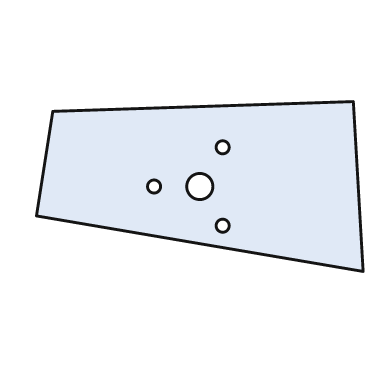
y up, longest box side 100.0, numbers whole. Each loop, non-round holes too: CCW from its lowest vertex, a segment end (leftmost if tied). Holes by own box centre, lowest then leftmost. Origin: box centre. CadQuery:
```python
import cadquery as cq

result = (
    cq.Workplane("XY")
    .moveTo(50.0, -26.0)
    .lineTo(47.0, 26.0)
    .lineTo(-45.0, 23.0)
    .lineTo(-50.0, -9.0)
    .close()
    .moveTo(7.0, -12.0)
    .circle(2.0)
    .moveTo(-14.0, 0.0)
    .circle(2.0)
    .moveTo(0.0, 0.0)
    .circle(4.0)
    .moveTo(7.0, 12.0)
    .circle(2.0)
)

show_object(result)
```